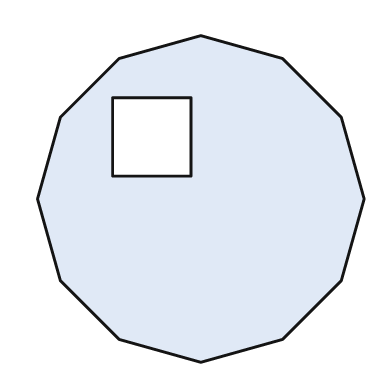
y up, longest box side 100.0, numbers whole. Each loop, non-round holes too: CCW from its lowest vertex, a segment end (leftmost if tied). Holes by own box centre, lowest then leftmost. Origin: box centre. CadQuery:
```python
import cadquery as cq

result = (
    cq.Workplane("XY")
    .moveTo(0.0, -50.0)
    .lineTo(25.0, -43.0)
    .lineTo(43.0, -25.0)
    .lineTo(50.0, 0.0)
    .lineTo(43.0, 25.0)
    .lineTo(25.0, 43.0)
    .lineTo(0.0, 50.0)
    .lineTo(-25.0, 43.0)
    .lineTo(-43.0, 25.0)
    .lineTo(-50.0, 0.0)
    .lineTo(-43.0, -25.0)
    .lineTo(-25.0, -43.0)
    .close()
    .moveTo(-27.0, 7.0)
    .lineTo(-3.0, 7.0)
    .lineTo(-3.0, 31.0)
    .lineTo(-27.0, 31.0)
    .close()
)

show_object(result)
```